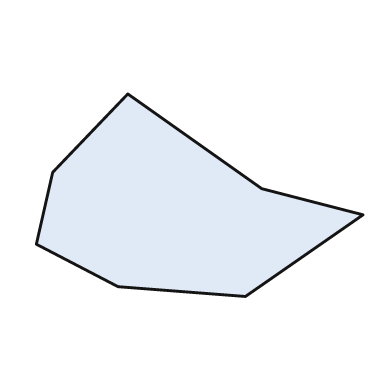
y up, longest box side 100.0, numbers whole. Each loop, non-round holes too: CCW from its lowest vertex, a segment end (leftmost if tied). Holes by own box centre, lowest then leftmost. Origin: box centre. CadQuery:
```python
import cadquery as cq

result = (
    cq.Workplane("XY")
    .moveTo(14.0, -31.0)
    .lineTo(50.0, -6.0)
    .lineTo(19.0, 2.0)
    .lineTo(-22.0, 31.0)
    .lineTo(-45.0, 7.0)
    .lineTo(-50.0, -15.0)
    .lineTo(-25.0, -28.0)
    .close()
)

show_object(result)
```